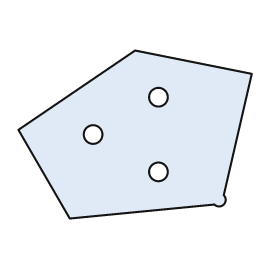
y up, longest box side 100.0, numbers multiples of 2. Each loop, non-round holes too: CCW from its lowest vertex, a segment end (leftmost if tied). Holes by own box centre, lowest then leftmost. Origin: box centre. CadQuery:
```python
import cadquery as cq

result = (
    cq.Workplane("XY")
    .moveTo(-28.0, -36.0)
    .lineTo(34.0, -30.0)
    .threePointArc((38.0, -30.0), (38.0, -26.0))
    .lineTo(50.0, 26.0)
    .lineTo(0.0, 36.0)
    .lineTo(-50.0, 2.0)
    .close()
    .moveTo(10.0, -16.0)
    .circle(4.0)
    .moveTo(-18.0, 0.0)
    .circle(4.0)
    .moveTo(10.0, 16.0)
    .circle(4.0)
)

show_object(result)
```